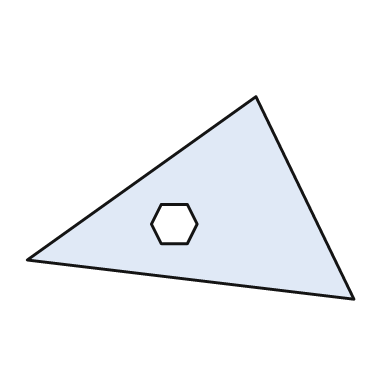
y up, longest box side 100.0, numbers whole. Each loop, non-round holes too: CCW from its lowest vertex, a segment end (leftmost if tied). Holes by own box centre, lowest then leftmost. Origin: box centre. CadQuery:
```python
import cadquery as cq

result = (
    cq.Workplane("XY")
    .moveTo(50.0, -31.0)
    .lineTo(20.0, 31.0)
    .lineTo(-50.0, -19.0)
    .close()
    .moveTo(-9.0, -14.0)
    .lineTo(-1.0, -14.0)
    .lineTo(2.0, -8.0)
    .lineTo(-1.0, -2.0)
    .lineTo(-9.0, -2.0)
    .lineTo(-12.0, -8.0)
    .close()
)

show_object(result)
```